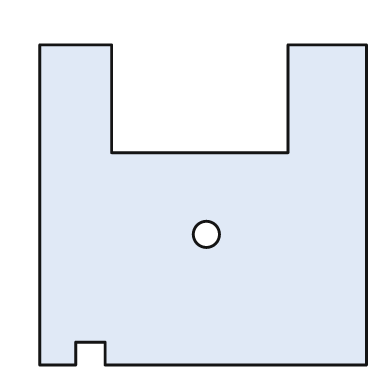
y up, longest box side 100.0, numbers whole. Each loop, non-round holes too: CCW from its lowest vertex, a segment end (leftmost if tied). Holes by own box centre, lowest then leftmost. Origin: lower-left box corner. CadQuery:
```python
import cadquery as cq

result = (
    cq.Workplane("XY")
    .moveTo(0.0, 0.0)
    .lineTo(11.0, 0.0)
    .lineTo(11.0, 7.0)
    .lineTo(20.0, 7.0)
    .lineTo(20.0, 0.0)
    .lineTo(100.0, 0.0)
    .lineTo(100.0, 98.0)
    .lineTo(76.0, 98.0)
    .lineTo(76.0, 65.0)
    .lineTo(22.0, 65.0)
    .lineTo(22.0, 98.0)
    .lineTo(0.0, 98.0)
    .close()
    .moveTo(51.0, 40.0)
    .circle(4.0)
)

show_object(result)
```